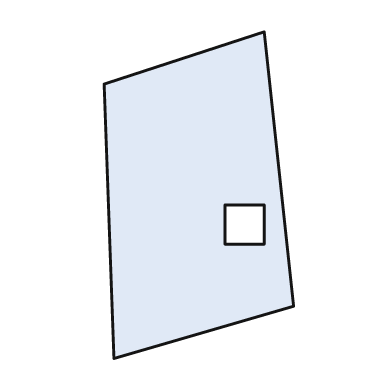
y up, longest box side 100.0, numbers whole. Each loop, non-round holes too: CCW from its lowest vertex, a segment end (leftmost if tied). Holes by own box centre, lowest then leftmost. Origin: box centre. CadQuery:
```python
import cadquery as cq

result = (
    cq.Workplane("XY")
    .moveTo(-26.0, -50.0)
    .lineTo(29.0, -34.0)
    .lineTo(20.0, 50.0)
    .lineTo(-29.0, 34.0)
    .close()
    .moveTo(8.0, -15.0)
    .lineTo(20.0, -15.0)
    .lineTo(20.0, -3.0)
    .lineTo(8.0, -3.0)
    .close()
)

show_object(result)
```